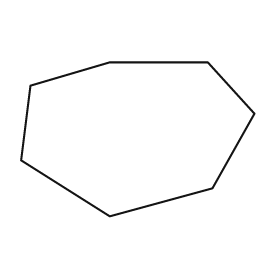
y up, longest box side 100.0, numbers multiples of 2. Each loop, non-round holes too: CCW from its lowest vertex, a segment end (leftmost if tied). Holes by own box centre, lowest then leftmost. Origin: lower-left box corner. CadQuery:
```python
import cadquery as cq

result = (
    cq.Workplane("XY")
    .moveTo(38.0, 0.0)
    .lineTo(82.0, 12.0)
    .lineTo(100.0, 44.0)
    .lineTo(80.0, 66.0)
    .lineTo(38.0, 66.0)
    .lineTo(4.0, 56.0)
    .lineTo(0.0, 24.0)
    .close()
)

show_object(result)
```